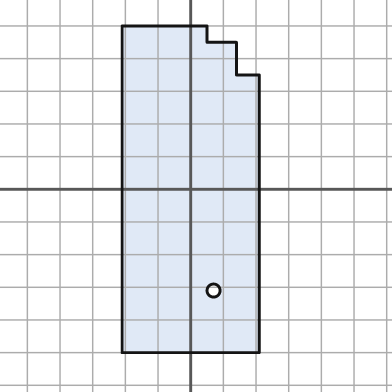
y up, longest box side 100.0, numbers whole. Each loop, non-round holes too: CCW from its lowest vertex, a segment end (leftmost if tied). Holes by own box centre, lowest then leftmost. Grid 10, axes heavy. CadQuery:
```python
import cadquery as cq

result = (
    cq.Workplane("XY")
    .moveTo(-21.0, -50.0)
    .lineTo(21.0, -50.0)
    .lineTo(21.0, 35.0)
    .lineTo(14.0, 35.0)
    .lineTo(14.0, 45.0)
    .lineTo(5.0, 45.0)
    .lineTo(5.0, 50.0)
    .lineTo(-21.0, 50.0)
    .close()
    .moveTo(7.0, -31.0)
    .circle(2.0)
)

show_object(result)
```